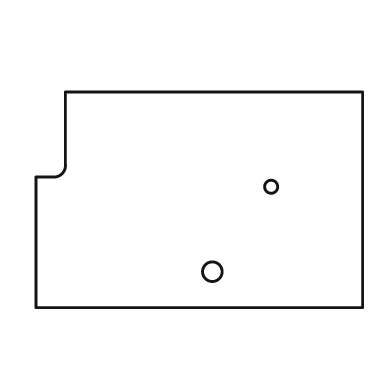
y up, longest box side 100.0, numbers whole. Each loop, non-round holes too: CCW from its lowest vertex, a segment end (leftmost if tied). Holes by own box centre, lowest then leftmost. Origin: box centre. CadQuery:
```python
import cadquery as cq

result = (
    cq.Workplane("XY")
    .moveTo(-50.0, -33.0)
    .lineTo(50.0, -33.0)
    .lineTo(50.0, 33.0)
    .lineTo(-41.0, 33.0)
    .lineTo(-41.0, 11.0)
    .threePointArc((-42.0, 8.0), (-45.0, 7.0))
    .lineTo(-50.0, 7.0)
    .close()
    .moveTo(4.0, -22.0)
    .circle(3.0)
    .moveTo(22.0, 4.0)
    .circle(2.0)
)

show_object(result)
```